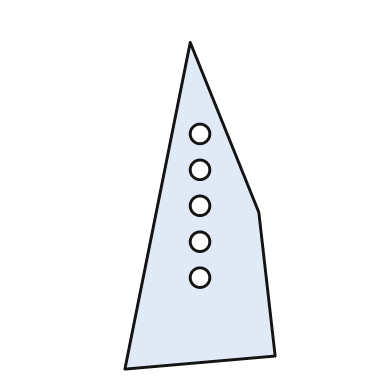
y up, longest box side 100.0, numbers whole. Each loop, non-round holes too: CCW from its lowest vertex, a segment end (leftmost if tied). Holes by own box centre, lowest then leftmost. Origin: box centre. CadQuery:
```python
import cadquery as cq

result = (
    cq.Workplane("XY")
    .moveTo(-23.0, -50.0)
    .lineTo(23.0, -46.0)
    .lineTo(18.0, -2.0)
    .lineTo(-3.0, 50.0)
    .close()
    .moveTo(0.0, -22.0)
    .circle(3.0)
    .moveTo(0.0, -11.0)
    .circle(3.0)
    .moveTo(0.0, 0.0)
    .circle(3.0)
    .moveTo(0.0, 11.0)
    .circle(3.0)
    .moveTo(0.0, 22.0)
    .circle(3.0)
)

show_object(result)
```